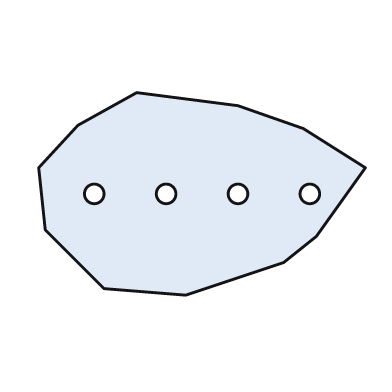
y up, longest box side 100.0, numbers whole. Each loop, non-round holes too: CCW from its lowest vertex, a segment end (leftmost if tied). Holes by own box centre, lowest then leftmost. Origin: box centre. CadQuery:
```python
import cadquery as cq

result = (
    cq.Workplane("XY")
    .moveTo(-5.0, -31.0)
    .lineTo(25.0, -21.0)
    .lineTo(35.0, -13.0)
    .lineTo(50.0, 8.0)
    .lineTo(31.0, 20.0)
    .lineTo(11.0, 27.0)
    .lineTo(-20.0, 31.0)
    .lineTo(-38.0, 21.0)
    .lineTo(-50.0, 8.0)
    .lineTo(-48.0, -11.0)
    .lineTo(-30.0, -29.0)
    .close()
    .moveTo(-33.0, 0.0)
    .circle(3.0)
    .moveTo(-11.0, 0.0)
    .circle(3.0)
    .moveTo(11.0, 0.0)
    .circle(3.0)
    .moveTo(33.0, 0.0)
    .circle(3.0)
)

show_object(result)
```